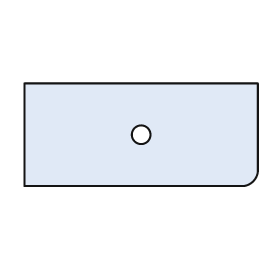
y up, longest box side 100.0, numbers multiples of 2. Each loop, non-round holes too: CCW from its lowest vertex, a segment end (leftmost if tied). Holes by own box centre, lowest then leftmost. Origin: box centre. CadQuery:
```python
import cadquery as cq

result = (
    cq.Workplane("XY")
    .moveTo(-50.0, -22.0)
    .lineTo(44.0, -22.0)
    .threePointArc((48.0, -20.0), (50.0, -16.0))
    .lineTo(50.0, 22.0)
    .lineTo(-50.0, 22.0)
    .close()
    .moveTo(0.0, 0.0)
    .circle(4.0)
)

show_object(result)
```